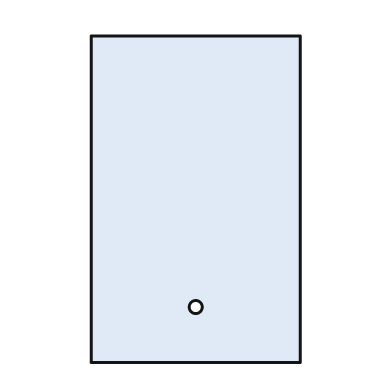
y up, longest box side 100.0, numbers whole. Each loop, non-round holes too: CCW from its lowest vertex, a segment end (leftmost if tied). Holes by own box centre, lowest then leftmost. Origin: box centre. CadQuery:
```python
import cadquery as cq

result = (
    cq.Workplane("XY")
    .moveTo(-32.0, -50.0)
    .lineTo(32.0, -50.0)
    .lineTo(32.0, 50.0)
    .lineTo(-32.0, 50.0)
    .close()
    .moveTo(0.0, -33.0)
    .circle(2.0)
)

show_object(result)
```